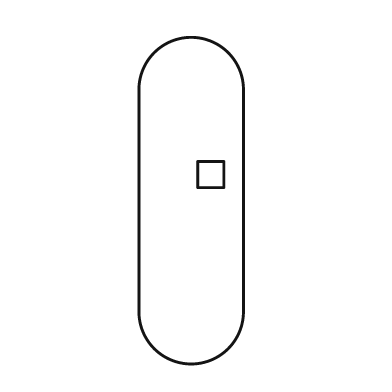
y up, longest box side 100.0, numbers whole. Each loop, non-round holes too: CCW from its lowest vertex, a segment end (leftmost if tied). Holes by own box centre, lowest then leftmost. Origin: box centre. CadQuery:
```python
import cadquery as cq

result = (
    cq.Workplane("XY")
    .moveTo(-16.0, -34.0)
    .threePointArc((0.0, -50.0), (16.0, -34.0))
    .lineTo(16.0, 34.0)
    .threePointArc((0.0, 50.0), (-16.0, 34.0))
    .close()
    .moveTo(2.0, 4.0)
    .lineTo(10.0, 4.0)
    .lineTo(10.0, 12.0)
    .lineTo(2.0, 12.0)
    .close()
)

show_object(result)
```